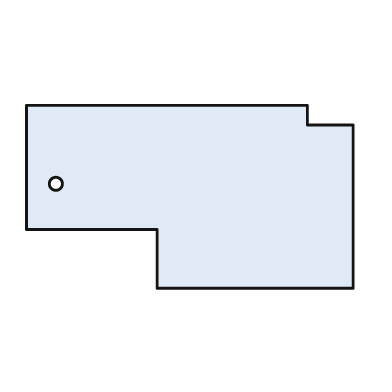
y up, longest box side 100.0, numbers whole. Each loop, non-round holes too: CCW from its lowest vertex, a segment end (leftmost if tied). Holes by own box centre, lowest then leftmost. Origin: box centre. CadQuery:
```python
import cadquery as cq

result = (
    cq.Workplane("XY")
    .moveTo(-10.0, -28.0)
    .lineTo(50.0, -28.0)
    .lineTo(50.0, 22.0)
    .lineTo(36.0, 22.0)
    .lineTo(36.0, 28.0)
    .lineTo(-50.0, 28.0)
    .lineTo(-50.0, -10.0)
    .lineTo(-10.0, -10.0)
    .close()
    .moveTo(-41.0, 4.0)
    .circle(2.0)
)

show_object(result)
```